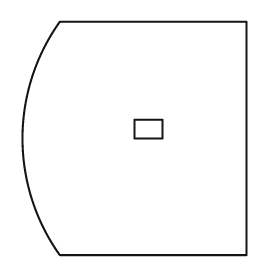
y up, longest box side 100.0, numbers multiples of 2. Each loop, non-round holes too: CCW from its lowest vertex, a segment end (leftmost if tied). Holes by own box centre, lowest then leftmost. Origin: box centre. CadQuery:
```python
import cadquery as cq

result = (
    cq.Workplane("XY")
    .moveTo(-32.0, -50.0)
    .lineTo(48.0, -50.0)
    .lineTo(48.0, 50.0)
    .lineTo(-32.0, 50.0)
    .threePointArc((-48.0, 0.0), (-32.0, -50.0))
    .close()
    .moveTo(0.0, 0.0)
    .lineTo(12.0, 0.0)
    .lineTo(12.0, 8.0)
    .lineTo(0.0, 8.0)
    .close()
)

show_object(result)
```